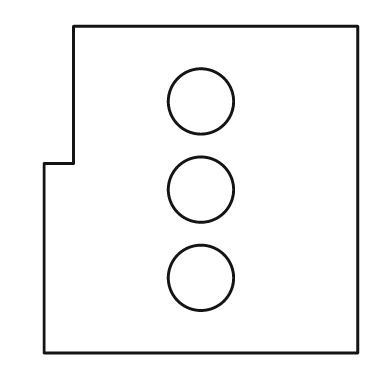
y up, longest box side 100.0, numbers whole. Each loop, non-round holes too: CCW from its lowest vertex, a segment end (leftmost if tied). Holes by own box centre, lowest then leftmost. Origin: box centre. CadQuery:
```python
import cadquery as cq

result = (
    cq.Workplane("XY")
    .moveTo(-48.0, -50.0)
    .lineTo(48.0, -50.0)
    .lineTo(48.0, 50.0)
    .lineTo(-39.0, 50.0)
    .lineTo(-39.0, 8.0)
    .lineTo(-48.0, 8.0)
    .close()
    .moveTo(0.0, -27.0)
    .circle(10.0)
    .moveTo(0.0, 0.0)
    .circle(10.0)
    .moveTo(0.0, 27.0)
    .circle(10.0)
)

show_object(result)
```